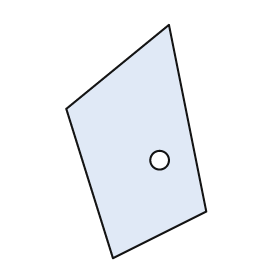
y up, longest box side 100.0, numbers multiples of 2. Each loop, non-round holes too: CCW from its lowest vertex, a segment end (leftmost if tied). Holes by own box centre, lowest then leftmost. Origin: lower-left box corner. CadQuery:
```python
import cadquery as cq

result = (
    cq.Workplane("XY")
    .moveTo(20.0, 0.0)
    .lineTo(60.0, 20.0)
    .lineTo(44.0, 100.0)
    .lineTo(0.0, 64.0)
    .close()
    .moveTo(40.0, 42.0)
    .circle(4.0)
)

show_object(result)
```